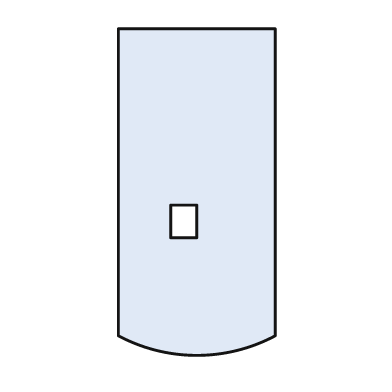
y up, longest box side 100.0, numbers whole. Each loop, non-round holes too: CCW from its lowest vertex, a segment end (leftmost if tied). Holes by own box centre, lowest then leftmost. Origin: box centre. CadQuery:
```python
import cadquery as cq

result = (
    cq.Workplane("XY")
    .moveTo(-24.0, -44.0)
    .threePointArc((0.0, -50.0), (24.0, -44.0))
    .lineTo(24.0, 50.0)
    .lineTo(-24.0, 50.0)
    .close()
    .moveTo(-8.0, -14.0)
    .lineTo(0.0, -14.0)
    .lineTo(0.0, -4.0)
    .lineTo(-8.0, -4.0)
    .close()
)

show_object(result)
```